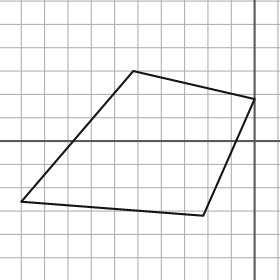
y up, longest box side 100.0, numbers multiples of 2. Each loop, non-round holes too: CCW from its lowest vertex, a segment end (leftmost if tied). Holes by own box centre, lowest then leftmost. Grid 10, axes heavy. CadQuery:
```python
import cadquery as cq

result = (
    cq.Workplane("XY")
    .moveTo(-22.0, -32.0)
    .lineTo(0.0, 18.0)
    .lineTo(-52.0, 30.0)
    .lineTo(-100.0, -26.0)
    .close()
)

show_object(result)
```